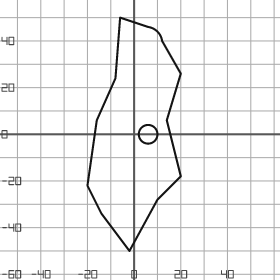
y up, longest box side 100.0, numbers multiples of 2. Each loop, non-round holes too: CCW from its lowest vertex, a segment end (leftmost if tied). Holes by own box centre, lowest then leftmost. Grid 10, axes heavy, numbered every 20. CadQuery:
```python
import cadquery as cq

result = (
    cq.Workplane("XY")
    .moveTo(-2.0, -50.0)
    .lineTo(10.0, -28.0)
    .lineTo(20.0, -18.0)
    .lineTo(14.0, 6.0)
    .lineTo(20.0, 26.0)
    .lineTo(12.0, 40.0)
    .threePointArc((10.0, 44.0), (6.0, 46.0))
    .lineTo(-6.0, 50.0)
    .lineTo(-8.0, 24.0)
    .lineTo(-16.0, 6.0)
    .lineTo(-20.0, -22.0)
    .lineTo(-14.0, -34.0)
    .close()
    .moveTo(6.0, 0.0)
    .circle(4.0)
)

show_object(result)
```